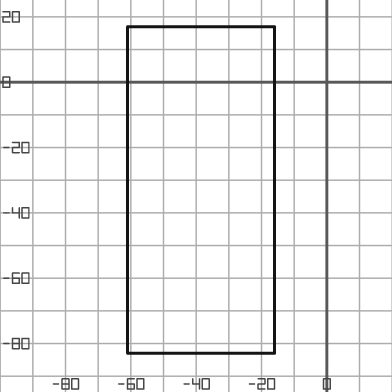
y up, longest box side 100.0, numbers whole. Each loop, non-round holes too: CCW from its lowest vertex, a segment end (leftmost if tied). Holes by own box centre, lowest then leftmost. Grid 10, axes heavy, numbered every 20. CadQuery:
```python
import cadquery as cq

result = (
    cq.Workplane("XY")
    .moveTo(-61.0, -83.0)
    .lineTo(-16.0, -83.0)
    .lineTo(-16.0, 17.0)
    .lineTo(-61.0, 17.0)
    .close()
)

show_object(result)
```